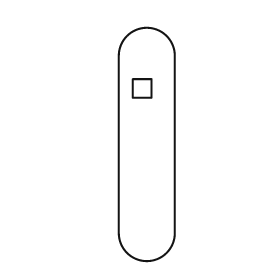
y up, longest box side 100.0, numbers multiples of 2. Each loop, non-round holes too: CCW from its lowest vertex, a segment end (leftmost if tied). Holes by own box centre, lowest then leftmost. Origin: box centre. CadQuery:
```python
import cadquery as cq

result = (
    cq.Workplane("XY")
    .moveTo(-12.0, -38.0)
    .threePointArc((0.0, -50.0), (12.0, -38.0))
    .lineTo(12.0, 38.0)
    .threePointArc((0.0, 50.0), (-12.0, 38.0))
    .close()
    .moveTo(-6.0, 20.0)
    .lineTo(2.0, 20.0)
    .lineTo(2.0, 28.0)
    .lineTo(-6.0, 28.0)
    .close()
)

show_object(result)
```